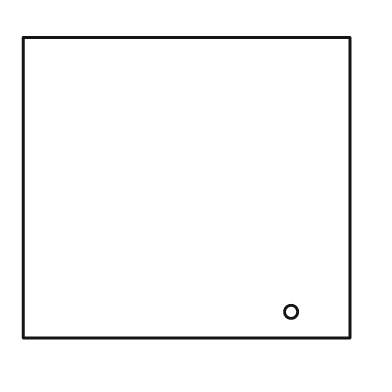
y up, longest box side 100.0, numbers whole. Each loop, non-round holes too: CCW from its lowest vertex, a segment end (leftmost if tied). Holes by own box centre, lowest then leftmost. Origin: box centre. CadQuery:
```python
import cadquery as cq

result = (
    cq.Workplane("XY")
    .moveTo(-50.0, -46.0)
    .lineTo(50.0, -46.0)
    .lineTo(50.0, 46.0)
    .lineTo(-50.0, 46.0)
    .close()
    .moveTo(32.0, -38.0)
    .circle(2.0)
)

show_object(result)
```